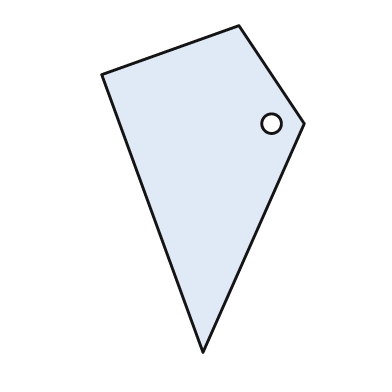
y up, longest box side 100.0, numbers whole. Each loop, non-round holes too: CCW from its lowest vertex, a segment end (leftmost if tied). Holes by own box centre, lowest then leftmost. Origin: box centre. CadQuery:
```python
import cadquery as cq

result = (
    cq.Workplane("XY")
    .moveTo(0.0, -50.0)
    .lineTo(31.0, 20.0)
    .lineTo(11.0, 50.0)
    .lineTo(-31.0, 35.0)
    .close()
    .moveTo(21.0, 20.0)
    .circle(3.0)
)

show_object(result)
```